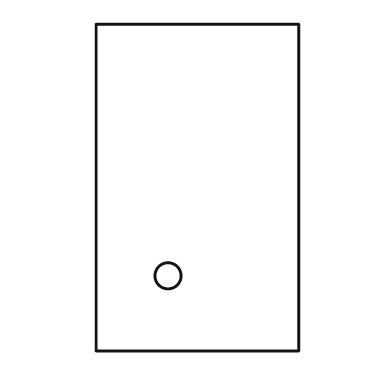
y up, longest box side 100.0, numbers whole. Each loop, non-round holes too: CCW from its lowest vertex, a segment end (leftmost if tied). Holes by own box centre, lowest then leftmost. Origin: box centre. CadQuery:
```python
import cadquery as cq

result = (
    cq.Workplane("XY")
    .moveTo(-31.0, -50.0)
    .lineTo(31.0, -50.0)
    .lineTo(31.0, 50.0)
    .lineTo(-31.0, 50.0)
    .close()
    .moveTo(-9.0, -27.0)
    .circle(4.0)
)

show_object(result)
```